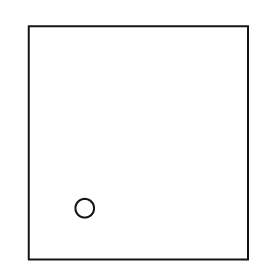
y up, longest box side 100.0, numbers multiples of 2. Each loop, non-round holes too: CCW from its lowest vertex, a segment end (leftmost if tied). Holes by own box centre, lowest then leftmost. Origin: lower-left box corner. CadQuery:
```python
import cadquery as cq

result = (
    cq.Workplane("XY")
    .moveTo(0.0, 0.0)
    .lineTo(94.0, 0.0)
    .lineTo(94.0, 100.0)
    .lineTo(0.0, 100.0)
    .close()
    .moveTo(24.0, 22.0)
    .circle(4.0)
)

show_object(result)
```